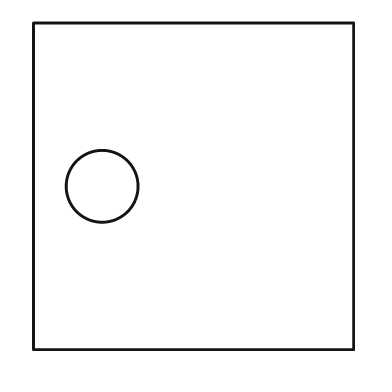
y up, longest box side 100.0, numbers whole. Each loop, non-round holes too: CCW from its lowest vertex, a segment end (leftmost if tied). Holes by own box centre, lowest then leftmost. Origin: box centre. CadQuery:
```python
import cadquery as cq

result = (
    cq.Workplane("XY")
    .moveTo(-49.0, -50.0)
    .lineTo(49.0, -50.0)
    .lineTo(49.0, 50.0)
    .lineTo(-49.0, 50.0)
    .close()
    .moveTo(-28.0, 0.0)
    .circle(11.0)
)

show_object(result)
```